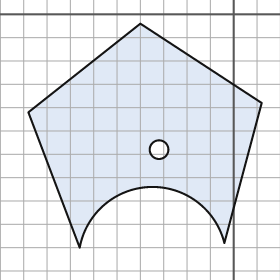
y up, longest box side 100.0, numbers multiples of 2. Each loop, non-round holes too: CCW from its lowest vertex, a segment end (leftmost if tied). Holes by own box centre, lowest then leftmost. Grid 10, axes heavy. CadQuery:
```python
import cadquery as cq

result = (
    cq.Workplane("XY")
    .moveTo(-66.0, -100.0)
    .threePointArc((-36.0, -74.0), (-4.0, -98.0))
    .lineTo(12.0, -38.0)
    .lineTo(-40.0, -4.0)
    .lineTo(-88.0, -42.0)
    .close()
    .moveTo(-32.0, -58.0)
    .circle(4.0)
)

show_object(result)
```